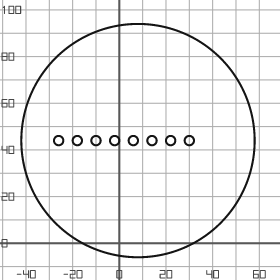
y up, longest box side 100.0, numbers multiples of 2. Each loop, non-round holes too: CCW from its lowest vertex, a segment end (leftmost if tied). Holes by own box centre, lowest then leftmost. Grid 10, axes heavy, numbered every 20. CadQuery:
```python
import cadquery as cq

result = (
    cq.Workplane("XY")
    .moveTo(8.0, 44.0)
    .circle(50.0)
    .moveTo(-26.0, 44.0)
    .circle(2.0)
    .moveTo(-18.0, 44.0)
    .circle(2.0)
    .moveTo(-10.0, 44.0)
    .circle(2.0)
    .moveTo(-2.0, 44.0)
    .circle(2.0)
    .moveTo(6.0, 44.0)
    .circle(2.0)
    .moveTo(14.0, 44.0)
    .circle(2.0)
    .moveTo(22.0, 44.0)
    .circle(2.0)
    .moveTo(30.0, 44.0)
    .circle(2.0)
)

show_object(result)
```